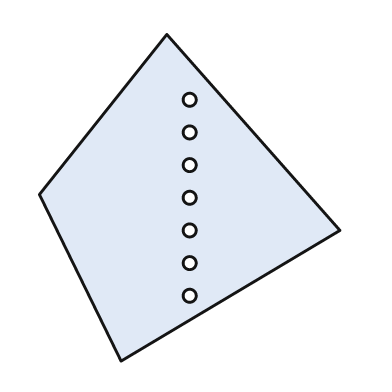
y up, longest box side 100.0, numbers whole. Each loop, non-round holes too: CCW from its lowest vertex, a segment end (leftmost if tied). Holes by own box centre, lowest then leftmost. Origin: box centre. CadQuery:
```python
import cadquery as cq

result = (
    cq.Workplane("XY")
    .moveTo(-21.0, -50.0)
    .lineTo(46.0, -10.0)
    .lineTo(-7.0, 50.0)
    .lineTo(-46.0, 1.0)
    .close()
    .moveTo(0.0, -30.0)
    .circle(2.0)
    .moveTo(0.0, -20.0)
    .circle(2.0)
    .moveTo(0.0, -10.0)
    .circle(2.0)
    .moveTo(0.0, 0.0)
    .circle(2.0)
    .moveTo(0.0, 10.0)
    .circle(2.0)
    .moveTo(0.0, 20.0)
    .circle(2.0)
    .moveTo(0.0, 30.0)
    .circle(2.0)
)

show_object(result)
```